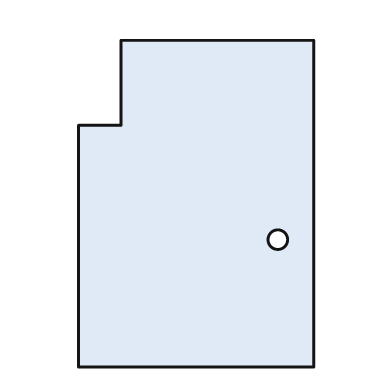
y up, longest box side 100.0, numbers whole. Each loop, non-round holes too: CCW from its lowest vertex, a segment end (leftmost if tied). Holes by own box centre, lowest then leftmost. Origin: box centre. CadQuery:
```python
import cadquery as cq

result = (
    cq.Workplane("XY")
    .moveTo(-36.0, -50.0)
    .lineTo(36.0, -50.0)
    .lineTo(36.0, 50.0)
    .lineTo(-23.0, 50.0)
    .lineTo(-23.0, 24.0)
    .lineTo(-36.0, 24.0)
    .close()
    .moveTo(25.0, -11.0)
    .circle(3.0)
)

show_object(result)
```